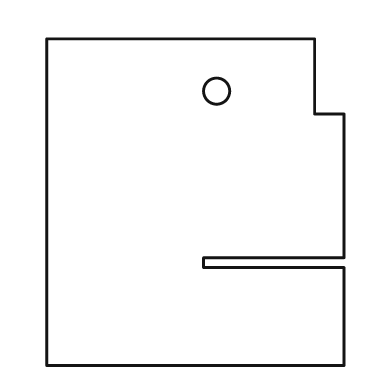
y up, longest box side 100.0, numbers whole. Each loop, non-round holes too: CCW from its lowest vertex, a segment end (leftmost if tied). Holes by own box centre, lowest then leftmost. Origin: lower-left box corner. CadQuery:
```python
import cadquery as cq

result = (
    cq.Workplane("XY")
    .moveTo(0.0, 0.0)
    .lineTo(91.0, 0.0)
    .lineTo(91.0, 30.0)
    .lineTo(48.0, 30.0)
    .lineTo(48.0, 33.0)
    .lineTo(91.0, 33.0)
    .lineTo(91.0, 77.0)
    .lineTo(82.0, 77.0)
    .lineTo(82.0, 100.0)
    .lineTo(0.0, 100.0)
    .close()
    .moveTo(52.0, 84.0)
    .circle(4.0)
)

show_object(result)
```